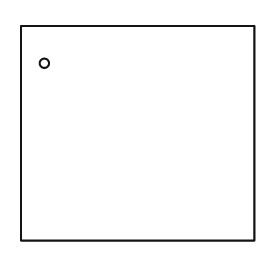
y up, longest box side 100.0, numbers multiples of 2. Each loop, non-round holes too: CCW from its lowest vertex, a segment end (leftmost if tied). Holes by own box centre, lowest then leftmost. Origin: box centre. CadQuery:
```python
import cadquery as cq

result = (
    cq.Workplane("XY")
    .moveTo(-50.0, -46.0)
    .lineTo(50.0, -46.0)
    .lineTo(50.0, 46.0)
    .lineTo(-50.0, 46.0)
    .close()
    .moveTo(-40.0, 30.0)
    .circle(2.0)
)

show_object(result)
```